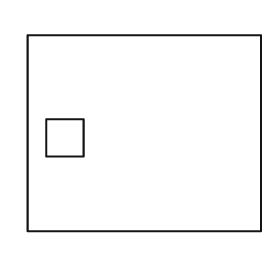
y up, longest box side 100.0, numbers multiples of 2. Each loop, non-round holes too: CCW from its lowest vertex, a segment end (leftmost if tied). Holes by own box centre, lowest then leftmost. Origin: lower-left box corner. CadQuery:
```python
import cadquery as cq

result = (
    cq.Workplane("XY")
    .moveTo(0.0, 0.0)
    .lineTo(100.0, 0.0)
    .lineTo(100.0, 84.0)
    .lineTo(0.0, 84.0)
    .close()
    .moveTo(8.0, 32.0)
    .lineTo(24.0, 32.0)
    .lineTo(24.0, 48.0)
    .lineTo(8.0, 48.0)
    .close()
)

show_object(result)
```